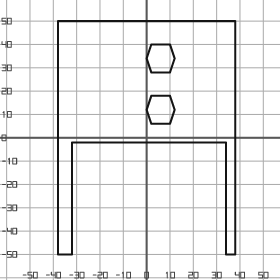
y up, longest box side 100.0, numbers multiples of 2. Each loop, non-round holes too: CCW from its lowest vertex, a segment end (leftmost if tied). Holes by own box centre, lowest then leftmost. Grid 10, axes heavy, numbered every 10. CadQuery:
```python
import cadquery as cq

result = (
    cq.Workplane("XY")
    .moveTo(-38.0, -50.0)
    .lineTo(-32.0, -50.0)
    .lineTo(-32.0, -2.0)
    .lineTo(34.0, -2.0)
    .lineTo(34.0, -50.0)
    .lineTo(38.0, -50.0)
    .lineTo(38.0, 50.0)
    .lineTo(-38.0, 50.0)
    .close()
    .moveTo(2.0, 6.0)
    .lineTo(10.0, 6.0)
    .lineTo(12.0, 12.0)
    .lineTo(10.0, 18.0)
    .lineTo(2.0, 18.0)
    .lineTo(0.0, 12.0)
    .close()
    .moveTo(2.0, 28.0)
    .lineTo(10.0, 28.0)
    .lineTo(12.0, 34.0)
    .lineTo(10.0, 40.0)
    .lineTo(2.0, 40.0)
    .lineTo(0.0, 34.0)
    .close()
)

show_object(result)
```